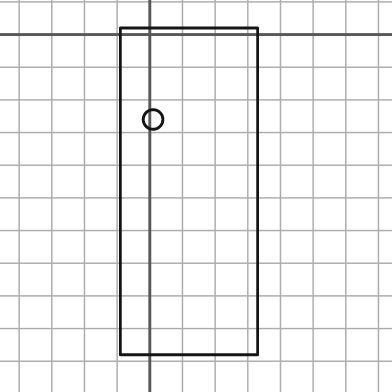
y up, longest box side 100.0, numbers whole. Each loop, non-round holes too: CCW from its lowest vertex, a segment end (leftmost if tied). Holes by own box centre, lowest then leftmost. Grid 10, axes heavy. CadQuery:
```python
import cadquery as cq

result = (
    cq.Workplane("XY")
    .moveTo(-9.0, -98.0)
    .lineTo(33.0, -98.0)
    .lineTo(33.0, 2.0)
    .lineTo(-9.0, 2.0)
    .close()
    .moveTo(1.0, -26.0)
    .circle(3.0)
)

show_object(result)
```